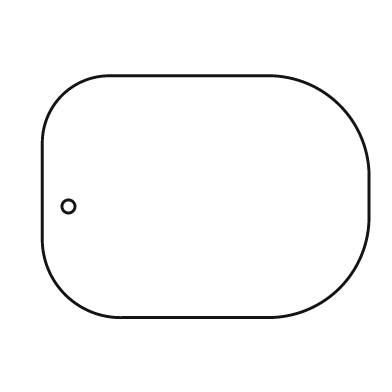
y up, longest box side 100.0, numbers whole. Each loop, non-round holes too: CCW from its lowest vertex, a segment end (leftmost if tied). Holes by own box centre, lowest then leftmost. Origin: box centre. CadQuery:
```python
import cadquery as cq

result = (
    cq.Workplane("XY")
    .moveTo(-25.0, -37.0)
    .lineTo(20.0, -37.0)
    .threePointArc((41.0, -28.0), (50.0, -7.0))
    .lineTo(50.0, 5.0)
    .threePointArc((41.0, 28.0), (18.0, 37.0))
    .lineTo(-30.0, 37.0)
    .threePointArc((-44.0, 31.0), (-50.0, 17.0))
    .lineTo(-50.0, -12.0)
    .threePointArc((-43.0, -30.0), (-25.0, -37.0))
    .close()
    .moveTo(-42.0, -3.0)
    .circle(2.0)
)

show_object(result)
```